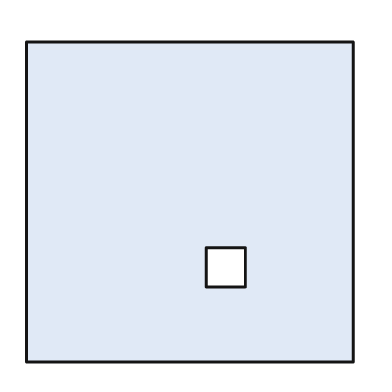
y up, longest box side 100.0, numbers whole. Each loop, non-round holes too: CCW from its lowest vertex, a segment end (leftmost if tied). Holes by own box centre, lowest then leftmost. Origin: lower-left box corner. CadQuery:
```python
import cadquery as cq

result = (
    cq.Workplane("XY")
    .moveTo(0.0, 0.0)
    .lineTo(100.0, 0.0)
    .lineTo(100.0, 98.0)
    .lineTo(0.0, 98.0)
    .close()
    .moveTo(55.0, 23.0)
    .lineTo(67.0, 23.0)
    .lineTo(67.0, 35.0)
    .lineTo(55.0, 35.0)
    .close()
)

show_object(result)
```